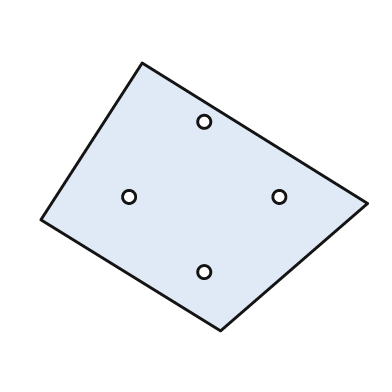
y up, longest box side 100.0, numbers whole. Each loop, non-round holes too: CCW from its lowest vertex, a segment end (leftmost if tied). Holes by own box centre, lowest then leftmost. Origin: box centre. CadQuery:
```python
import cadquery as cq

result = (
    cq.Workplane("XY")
    .moveTo(5.0, -41.0)
    .lineTo(50.0, -2.0)
    .lineTo(-19.0, 41.0)
    .lineTo(-50.0, -7.0)
    .close()
    .moveTo(0.0, -23.0)
    .circle(2.0)
    .moveTo(-23.0, 0.0)
    .circle(2.0)
    .moveTo(23.0, 0.0)
    .circle(2.0)
    .moveTo(0.0, 23.0)
    .circle(2.0)
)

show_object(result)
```